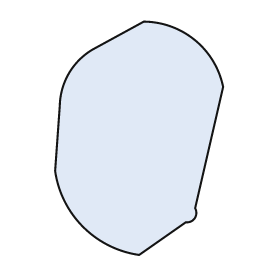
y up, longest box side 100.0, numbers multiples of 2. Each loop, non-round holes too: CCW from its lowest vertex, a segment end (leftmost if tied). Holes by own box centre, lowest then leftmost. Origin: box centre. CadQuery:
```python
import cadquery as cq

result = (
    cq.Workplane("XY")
    .moveTo(0.0, -50.0)
    .lineTo(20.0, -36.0)
    .threePointArc((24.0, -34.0), (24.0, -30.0))
    .lineTo(36.0, 22.0)
    .threePointArc((24.0, 42.0), (2.0, 50.0))
    .lineTo(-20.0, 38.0)
    .threePointArc((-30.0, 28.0), (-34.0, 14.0))
    .lineTo(-36.0, -14.0)
    .threePointArc((-24.0, -38.0), (0.0, -50.0))
    .close()
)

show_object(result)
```